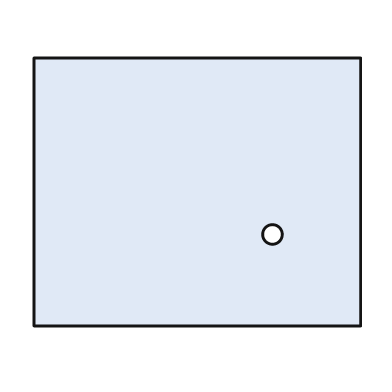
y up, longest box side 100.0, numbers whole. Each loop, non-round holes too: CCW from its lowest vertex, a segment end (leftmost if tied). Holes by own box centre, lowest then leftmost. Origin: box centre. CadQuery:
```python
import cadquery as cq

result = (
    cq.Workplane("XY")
    .moveTo(-50.0, -41.0)
    .lineTo(50.0, -41.0)
    .lineTo(50.0, 41.0)
    .lineTo(-50.0, 41.0)
    .close()
    .moveTo(23.0, -13.0)
    .circle(3.0)
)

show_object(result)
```